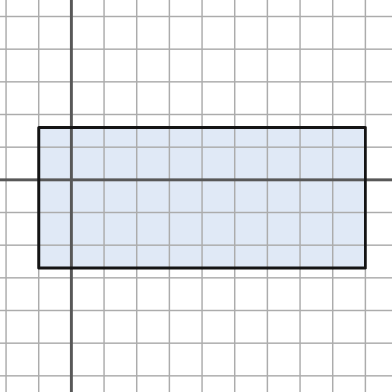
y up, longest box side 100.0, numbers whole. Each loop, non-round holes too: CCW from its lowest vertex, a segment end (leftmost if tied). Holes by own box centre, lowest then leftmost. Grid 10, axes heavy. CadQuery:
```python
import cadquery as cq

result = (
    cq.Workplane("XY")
    .moveTo(-10.0, -27.0)
    .lineTo(90.0, -27.0)
    .lineTo(90.0, 16.0)
    .lineTo(-10.0, 16.0)
    .close()
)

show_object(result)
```